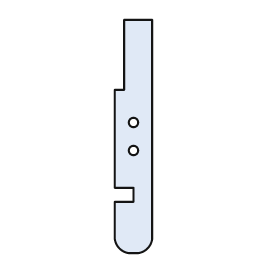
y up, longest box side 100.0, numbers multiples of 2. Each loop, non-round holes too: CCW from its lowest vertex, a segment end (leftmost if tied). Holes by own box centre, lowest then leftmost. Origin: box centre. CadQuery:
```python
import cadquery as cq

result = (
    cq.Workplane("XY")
    .moveTo(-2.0, -50.0)
    .lineTo(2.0, -50.0)
    .threePointArc((6.0, -48.0), (8.0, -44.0))
    .lineTo(8.0, 50.0)
    .lineTo(-4.0, 50.0)
    .lineTo(-4.0, 20.0)
    .lineTo(-8.0, 20.0)
    .lineTo(-8.0, -22.0)
    .lineTo(0.0, -22.0)
    .lineTo(0.0, -28.0)
    .lineTo(-8.0, -28.0)
    .lineTo(-8.0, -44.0)
    .threePointArc((-6.0, -48.0), (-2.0, -50.0))
    .close()
    .moveTo(0.0, -6.0)
    .circle(2.0)
    .moveTo(0.0, 6.0)
    .circle(2.0)
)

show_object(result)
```